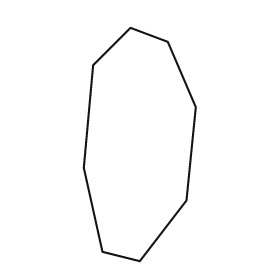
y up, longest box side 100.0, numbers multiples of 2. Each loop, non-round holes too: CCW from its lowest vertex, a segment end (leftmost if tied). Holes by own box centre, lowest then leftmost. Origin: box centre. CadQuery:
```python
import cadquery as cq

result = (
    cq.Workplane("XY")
    .moveTo(0.0, -50.0)
    .lineTo(20.0, -24.0)
    .lineTo(24.0, 16.0)
    .lineTo(12.0, 44.0)
    .lineTo(-4.0, 50.0)
    .lineTo(-20.0, 34.0)
    .lineTo(-24.0, -10.0)
    .lineTo(-16.0, -46.0)
    .close()
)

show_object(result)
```